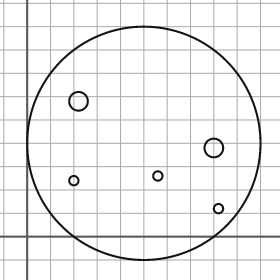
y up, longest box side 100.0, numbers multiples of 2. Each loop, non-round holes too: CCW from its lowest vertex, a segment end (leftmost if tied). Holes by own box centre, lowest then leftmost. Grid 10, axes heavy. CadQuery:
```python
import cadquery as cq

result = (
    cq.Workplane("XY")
    .moveTo(50.0, 40.0)
    .circle(50.0)
    .moveTo(82.0, 12.0)
    .circle(2.0)
    .moveTo(20.0, 24.0)
    .circle(2.0)
    .moveTo(56.0, 26.0)
    .circle(2.0)
    .moveTo(80.0, 38.0)
    .circle(4.0)
    .moveTo(22.0, 58.0)
    .circle(4.0)
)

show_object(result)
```